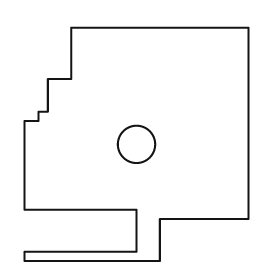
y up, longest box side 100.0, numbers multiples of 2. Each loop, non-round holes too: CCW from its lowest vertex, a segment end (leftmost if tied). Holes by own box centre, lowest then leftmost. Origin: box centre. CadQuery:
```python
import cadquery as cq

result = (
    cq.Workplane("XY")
    .moveTo(-48.0, -50.0)
    .lineTo(10.0, -50.0)
    .lineTo(10.0, -32.0)
    .lineTo(48.0, -32.0)
    .lineTo(48.0, 50.0)
    .lineTo(-28.0, 50.0)
    .lineTo(-28.0, 28.0)
    .lineTo(-38.0, 28.0)
    .lineTo(-38.0, 14.0)
    .lineTo(-42.0, 14.0)
    .lineTo(-42.0, 10.0)
    .lineTo(-48.0, 10.0)
    .lineTo(-48.0, -28.0)
    .lineTo(0.0, -28.0)
    .lineTo(0.0, -46.0)
    .lineTo(-48.0, -46.0)
    .close()
    .moveTo(0.0, 0.0)
    .circle(8.0)
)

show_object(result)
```